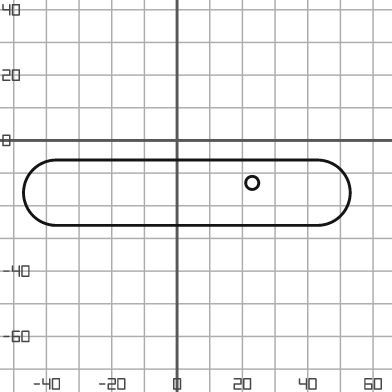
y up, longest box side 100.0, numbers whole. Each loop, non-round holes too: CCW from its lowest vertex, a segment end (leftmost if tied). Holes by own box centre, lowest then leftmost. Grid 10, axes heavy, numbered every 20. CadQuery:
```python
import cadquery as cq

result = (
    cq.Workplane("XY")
    .moveTo(-37.0, -26.0)
    .lineTo(43.0, -26.0)
    .threePointArc((53.0, -16.0), (43.0, -6.0))
    .lineTo(-37.0, -6.0)
    .threePointArc((-47.0, -16.0), (-37.0, -26.0))
    .close()
    .moveTo(23.0, -13.0)
    .circle(2.0)
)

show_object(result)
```